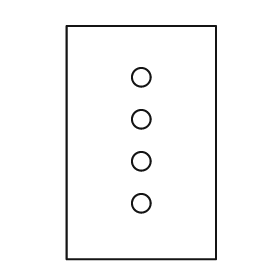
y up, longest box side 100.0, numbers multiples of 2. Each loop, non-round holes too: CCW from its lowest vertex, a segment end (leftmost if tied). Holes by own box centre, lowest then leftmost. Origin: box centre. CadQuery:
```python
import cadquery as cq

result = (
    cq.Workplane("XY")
    .moveTo(-32.0, -50.0)
    .lineTo(32.0, -50.0)
    .lineTo(32.0, 50.0)
    .lineTo(-32.0, 50.0)
    .close()
    .moveTo(0.0, -26.0)
    .circle(4.0)
    .moveTo(0.0, -8.0)
    .circle(4.0)
    .moveTo(0.0, 10.0)
    .circle(4.0)
    .moveTo(0.0, 28.0)
    .circle(4.0)
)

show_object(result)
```